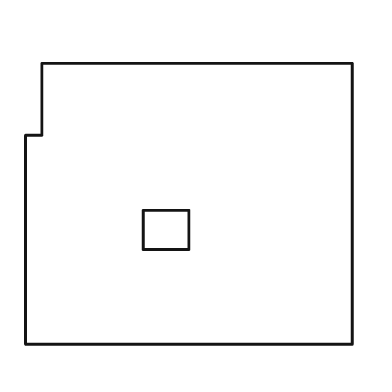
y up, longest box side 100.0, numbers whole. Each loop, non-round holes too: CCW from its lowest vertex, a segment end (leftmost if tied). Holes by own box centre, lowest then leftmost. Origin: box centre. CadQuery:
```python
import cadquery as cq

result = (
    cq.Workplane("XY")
    .moveTo(-50.0, -43.0)
    .lineTo(50.0, -43.0)
    .lineTo(50.0, 43.0)
    .lineTo(-45.0, 43.0)
    .lineTo(-45.0, 21.0)
    .lineTo(-50.0, 21.0)
    .close()
    .moveTo(-14.0, -14.0)
    .lineTo(0.0, -14.0)
    .lineTo(0.0, -2.0)
    .lineTo(-14.0, -2.0)
    .close()
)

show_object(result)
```